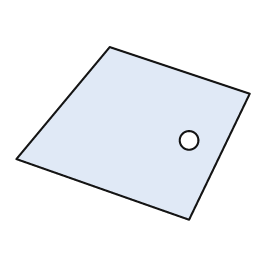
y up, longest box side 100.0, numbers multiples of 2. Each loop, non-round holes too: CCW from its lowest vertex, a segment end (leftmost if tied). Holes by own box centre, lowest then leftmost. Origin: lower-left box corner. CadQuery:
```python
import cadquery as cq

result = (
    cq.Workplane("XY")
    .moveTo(74.0, 0.0)
    .lineTo(100.0, 54.0)
    .lineTo(40.0, 74.0)
    .lineTo(0.0, 26.0)
    .close()
    .moveTo(74.0, 34.0)
    .circle(4.0)
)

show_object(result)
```